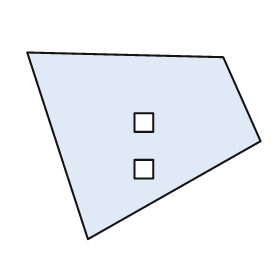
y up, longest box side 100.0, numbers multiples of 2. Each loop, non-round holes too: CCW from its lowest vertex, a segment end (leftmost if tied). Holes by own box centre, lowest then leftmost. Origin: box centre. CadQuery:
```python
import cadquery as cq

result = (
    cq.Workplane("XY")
    .moveTo(-24.0, -40.0)
    .lineTo(50.0, 2.0)
    .lineTo(34.0, 38.0)
    .lineTo(-50.0, 40.0)
    .close()
    .moveTo(-4.0, -14.0)
    .lineTo(4.0, -14.0)
    .lineTo(4.0, -6.0)
    .lineTo(-4.0, -6.0)
    .close()
    .moveTo(-4.0, 6.0)
    .lineTo(4.0, 6.0)
    .lineTo(4.0, 14.0)
    .lineTo(-4.0, 14.0)
    .close()
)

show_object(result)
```